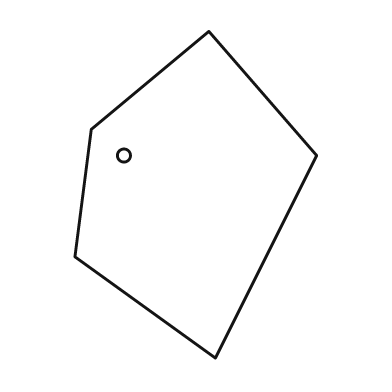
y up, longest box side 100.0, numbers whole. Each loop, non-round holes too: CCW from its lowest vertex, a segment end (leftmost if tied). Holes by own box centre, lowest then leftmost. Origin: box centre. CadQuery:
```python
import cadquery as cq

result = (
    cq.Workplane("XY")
    .moveTo(6.0, -50.0)
    .lineTo(37.0, 12.0)
    .lineTo(4.0, 50.0)
    .lineTo(-32.0, 20.0)
    .lineTo(-37.0, -19.0)
    .close()
    .moveTo(-22.0, 12.0)
    .circle(2.0)
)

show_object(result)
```